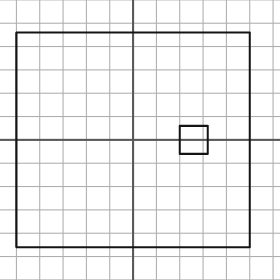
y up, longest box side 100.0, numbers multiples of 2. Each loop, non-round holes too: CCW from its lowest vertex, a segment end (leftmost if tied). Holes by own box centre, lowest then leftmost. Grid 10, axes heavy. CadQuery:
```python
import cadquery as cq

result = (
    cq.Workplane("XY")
    .moveTo(-50.0, -46.0)
    .lineTo(50.0, -46.0)
    .lineTo(50.0, 46.0)
    .lineTo(-50.0, 46.0)
    .close()
    .moveTo(20.0, -6.0)
    .lineTo(32.0, -6.0)
    .lineTo(32.0, 6.0)
    .lineTo(20.0, 6.0)
    .close()
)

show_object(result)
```